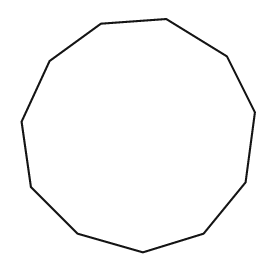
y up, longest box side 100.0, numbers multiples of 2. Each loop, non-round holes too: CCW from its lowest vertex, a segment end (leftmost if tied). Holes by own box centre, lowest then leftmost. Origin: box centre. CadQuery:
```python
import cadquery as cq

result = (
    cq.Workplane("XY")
    .moveTo(2.0, -50.0)
    .lineTo(28.0, -42.0)
    .lineTo(46.0, -20.0)
    .lineTo(50.0, 10.0)
    .lineTo(38.0, 34.0)
    .lineTo(12.0, 50.0)
    .lineTo(-16.0, 48.0)
    .lineTo(-38.0, 32.0)
    .lineTo(-50.0, 6.0)
    .lineTo(-46.0, -22.0)
    .lineTo(-26.0, -42.0)
    .close()
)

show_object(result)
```